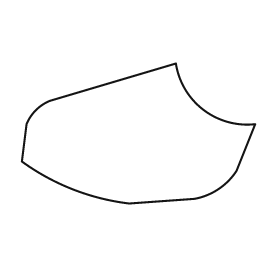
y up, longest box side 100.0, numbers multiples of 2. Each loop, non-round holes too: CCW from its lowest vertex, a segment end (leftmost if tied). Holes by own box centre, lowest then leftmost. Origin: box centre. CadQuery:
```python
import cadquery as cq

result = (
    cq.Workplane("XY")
    .moveTo(-4.0, -30.0)
    .lineTo(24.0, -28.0)
    .threePointArc((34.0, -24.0), (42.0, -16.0))
    .lineTo(50.0, 4.0)
    .threePointArc((28.0, 10.0), (16.0, 30.0))
    .lineTo(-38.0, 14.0)
    .threePointArc((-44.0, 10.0), (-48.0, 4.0))
    .lineTo(-50.0, -12.0)
    .threePointArc((-28.0, -24.0), (-4.0, -30.0))
    .close()
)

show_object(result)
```